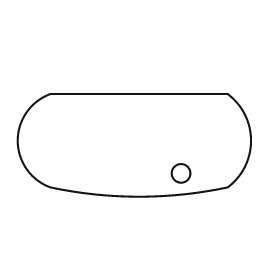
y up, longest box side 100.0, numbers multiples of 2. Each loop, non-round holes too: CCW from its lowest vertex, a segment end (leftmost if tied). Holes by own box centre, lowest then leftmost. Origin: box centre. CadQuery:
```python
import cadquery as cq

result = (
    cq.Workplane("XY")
    .moveTo(-36.0, -18.0)
    .threePointArc((2.0, -22.0), (40.0, -18.0))
    .threePointArc((50.0, 2.0), (40.0, 22.0))
    .lineTo(-36.0, 22.0)
    .threePointArc((-50.0, 2.0), (-36.0, -18.0))
    .close()
    .moveTo(20.0, -12.0)
    .circle(4.0)
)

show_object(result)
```